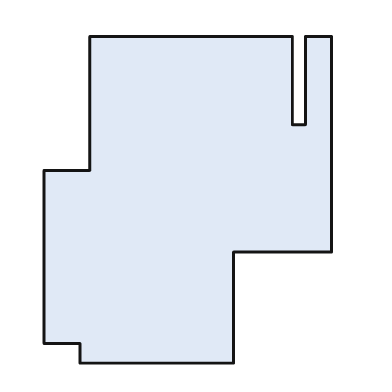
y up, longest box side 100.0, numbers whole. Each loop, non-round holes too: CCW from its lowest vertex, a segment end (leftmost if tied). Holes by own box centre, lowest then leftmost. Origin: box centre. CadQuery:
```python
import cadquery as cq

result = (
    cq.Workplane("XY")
    .moveTo(-33.0, -50.0)
    .lineTo(14.0, -50.0)
    .lineTo(14.0, -16.0)
    .lineTo(44.0, -16.0)
    .lineTo(44.0, 50.0)
    .lineTo(36.0, 50.0)
    .lineTo(36.0, 23.0)
    .lineTo(32.0, 23.0)
    .lineTo(32.0, 50.0)
    .lineTo(-30.0, 50.0)
    .lineTo(-30.0, 9.0)
    .lineTo(-44.0, 9.0)
    .lineTo(-44.0, -44.0)
    .lineTo(-33.0, -44.0)
    .close()
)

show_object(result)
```